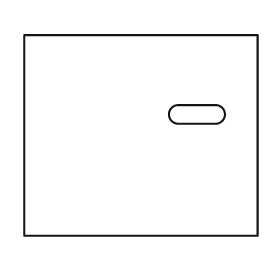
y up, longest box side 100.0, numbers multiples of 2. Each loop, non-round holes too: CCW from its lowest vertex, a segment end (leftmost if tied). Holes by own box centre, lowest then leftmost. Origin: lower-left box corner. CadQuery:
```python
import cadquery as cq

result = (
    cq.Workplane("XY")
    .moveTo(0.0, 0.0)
    .lineTo(100.0, 0.0)
    .lineTo(100.0, 86.0)
    .lineTo(0.0, 86.0)
    .close()
    .moveTo(66.0, 48.0)
    .lineTo(82.0, 48.0)
    .threePointArc((86.0, 52.0), (82.0, 56.0))
    .lineTo(66.0, 56.0)
    .threePointArc((62.0, 52.0), (66.0, 48.0))
    .close()
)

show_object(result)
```